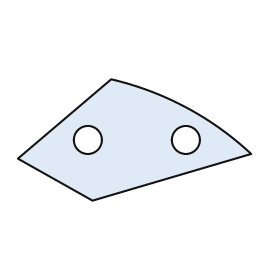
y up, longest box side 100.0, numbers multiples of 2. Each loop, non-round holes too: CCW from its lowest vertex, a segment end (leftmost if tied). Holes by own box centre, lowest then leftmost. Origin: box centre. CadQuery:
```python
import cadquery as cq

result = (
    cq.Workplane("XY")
    .moveTo(-18.0, -26.0)
    .lineTo(50.0, -6.0)
    .threePointArc((22.0, 14.0), (-10.0, 26.0))
    .lineTo(-50.0, -8.0)
    .close()
    .moveTo(-20.0, 0.0)
    .circle(6.0)
    .moveTo(22.0, 0.0)
    .circle(6.0)
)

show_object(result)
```